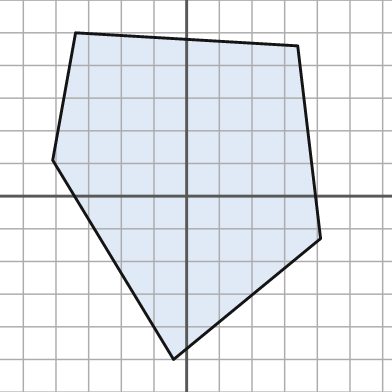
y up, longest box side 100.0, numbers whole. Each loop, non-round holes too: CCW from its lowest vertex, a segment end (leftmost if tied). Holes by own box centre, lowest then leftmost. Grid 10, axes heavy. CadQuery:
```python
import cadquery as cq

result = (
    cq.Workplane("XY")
    .moveTo(-4.0, -50.0)
    .lineTo(41.0, -13.0)
    .lineTo(34.0, 46.0)
    .lineTo(-34.0, 50.0)
    .lineTo(-41.0, 11.0)
    .close()
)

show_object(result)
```